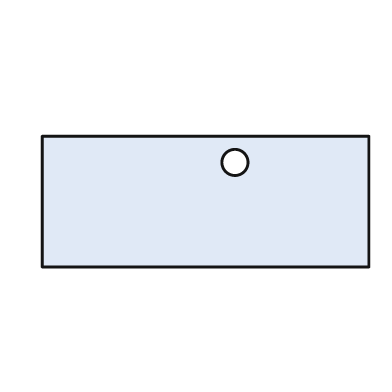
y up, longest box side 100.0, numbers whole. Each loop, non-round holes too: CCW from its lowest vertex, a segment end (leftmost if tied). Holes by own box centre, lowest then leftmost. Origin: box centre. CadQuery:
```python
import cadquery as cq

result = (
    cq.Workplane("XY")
    .moveTo(-50.0, -20.0)
    .lineTo(50.0, -20.0)
    .lineTo(50.0, 20.0)
    .lineTo(-50.0, 20.0)
    .close()
    .moveTo(9.0, 12.0)
    .circle(4.0)
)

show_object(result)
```